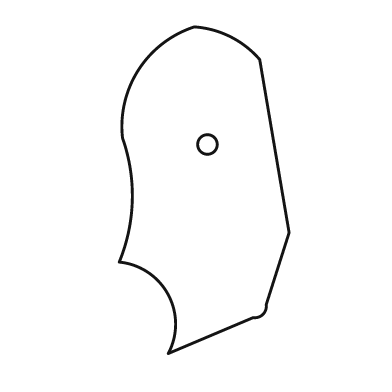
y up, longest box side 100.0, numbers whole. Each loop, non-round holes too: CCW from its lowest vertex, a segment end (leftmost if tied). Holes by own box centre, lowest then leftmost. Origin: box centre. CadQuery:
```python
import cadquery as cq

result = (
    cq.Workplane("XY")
    .moveTo(-11.0, -50.0)
    .lineTo(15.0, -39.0)
    .threePointArc((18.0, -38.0), (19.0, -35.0))
    .lineTo(26.0, -13.0)
    .lineTo(17.0, 40.0)
    .threePointArc((8.0, 47.0), (-3.0, 50.0))
    .threePointArc((-20.0, 37.0), (-25.0, 16.0))
    .threePointArc((-22.0, -3.0), (-26.0, -22.0))
    .threePointArc((-11.0, -32.0), (-11.0, -50.0))
    .close()
    .moveTo(1.0, 14.0)
    .circle(3.0)
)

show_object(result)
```